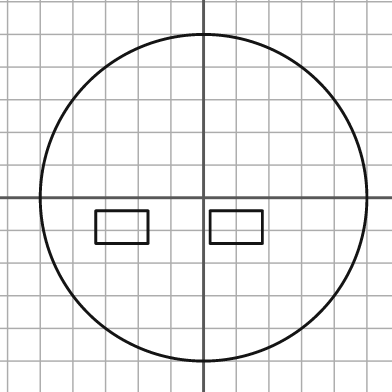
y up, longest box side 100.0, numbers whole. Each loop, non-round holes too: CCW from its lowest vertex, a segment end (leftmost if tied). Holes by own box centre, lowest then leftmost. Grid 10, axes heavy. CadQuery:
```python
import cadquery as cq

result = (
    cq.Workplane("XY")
    .moveTo(0.0, 0.0)
    .circle(50.0)
    .moveTo(-33.0, -14.0)
    .lineTo(-17.0, -14.0)
    .lineTo(-17.0, -4.0)
    .lineTo(-33.0, -4.0)
    .close()
    .moveTo(2.0, -14.0)
    .lineTo(18.0, -14.0)
    .lineTo(18.0, -4.0)
    .lineTo(2.0, -4.0)
    .close()
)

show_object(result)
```